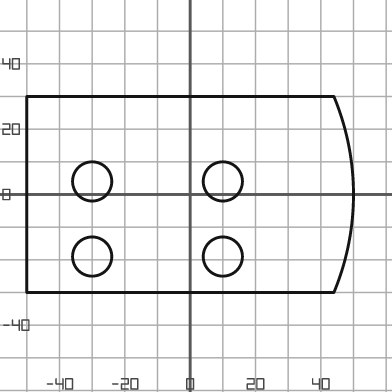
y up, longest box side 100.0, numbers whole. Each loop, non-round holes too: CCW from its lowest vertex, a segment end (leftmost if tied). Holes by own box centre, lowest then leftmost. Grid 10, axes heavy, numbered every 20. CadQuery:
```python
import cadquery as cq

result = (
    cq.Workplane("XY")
    .moveTo(-50.0, -30.0)
    .lineTo(44.0, -30.0)
    .threePointArc((50.0, 0.0), (44.0, 30.0))
    .lineTo(-50.0, 30.0)
    .close()
    .moveTo(-30.0, -19.0)
    .circle(6.0)
    .moveTo(10.0, -19.0)
    .circle(6.0)
    .moveTo(-30.0, 4.0)
    .circle(6.0)
    .moveTo(10.0, 4.0)
    .circle(6.0)
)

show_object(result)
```